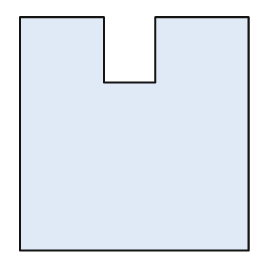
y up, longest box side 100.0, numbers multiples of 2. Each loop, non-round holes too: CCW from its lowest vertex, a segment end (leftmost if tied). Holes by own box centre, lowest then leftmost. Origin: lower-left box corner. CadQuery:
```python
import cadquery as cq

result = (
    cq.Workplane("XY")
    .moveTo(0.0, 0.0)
    .lineTo(98.0, 0.0)
    .lineTo(98.0, 100.0)
    .lineTo(58.0, 100.0)
    .lineTo(58.0, 72.0)
    .lineTo(36.0, 72.0)
    .lineTo(36.0, 100.0)
    .lineTo(0.0, 100.0)
    .close()
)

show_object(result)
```